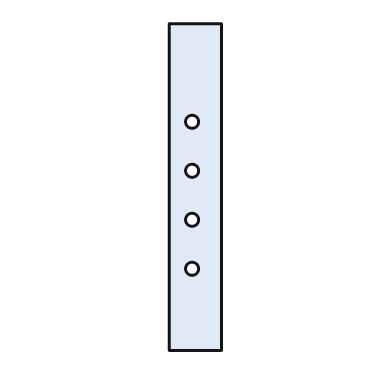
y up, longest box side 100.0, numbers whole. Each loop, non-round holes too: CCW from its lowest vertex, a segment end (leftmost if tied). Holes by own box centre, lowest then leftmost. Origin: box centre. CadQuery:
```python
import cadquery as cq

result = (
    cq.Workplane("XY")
    .moveTo(-8.0, -50.0)
    .lineTo(8.0, -50.0)
    .lineTo(8.0, 50.0)
    .lineTo(-8.0, 50.0)
    .close()
    .moveTo(-1.0, -25.0)
    .circle(2.0)
    .moveTo(-1.0, -10.0)
    .circle(2.0)
    .moveTo(-1.0, 5.0)
    .circle(2.0)
    .moveTo(-1.0, 20.0)
    .circle(2.0)
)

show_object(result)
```